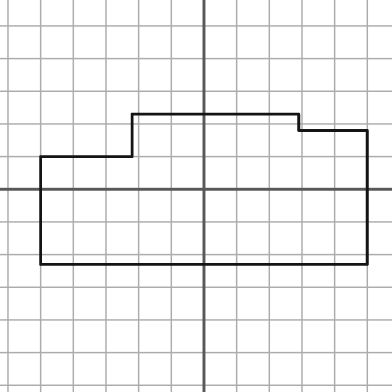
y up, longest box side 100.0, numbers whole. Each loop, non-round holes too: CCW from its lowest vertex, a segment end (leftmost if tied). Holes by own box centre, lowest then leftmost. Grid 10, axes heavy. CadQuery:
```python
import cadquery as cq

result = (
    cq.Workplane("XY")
    .moveTo(-50.0, -23.0)
    .lineTo(50.0, -23.0)
    .lineTo(50.0, 18.0)
    .lineTo(29.0, 18.0)
    .lineTo(29.0, 23.0)
    .lineTo(-22.0, 23.0)
    .lineTo(-22.0, 10.0)
    .lineTo(-50.0, 10.0)
    .close()
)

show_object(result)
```